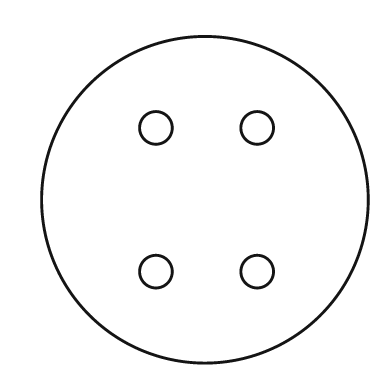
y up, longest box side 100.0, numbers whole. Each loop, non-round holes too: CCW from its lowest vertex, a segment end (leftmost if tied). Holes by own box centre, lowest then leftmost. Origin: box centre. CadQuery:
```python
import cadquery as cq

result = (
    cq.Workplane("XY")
    .moveTo(0.0, 0.0)
    .circle(50.0)
    .moveTo(-15.0, -22.0)
    .circle(5.0)
    .moveTo(16.0, -22.0)
    .circle(5.0)
    .moveTo(-15.0, 22.0)
    .circle(5.0)
    .moveTo(16.0, 22.0)
    .circle(5.0)
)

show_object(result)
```